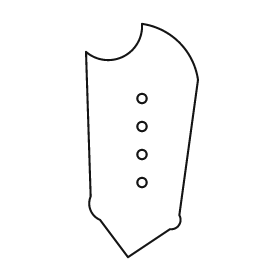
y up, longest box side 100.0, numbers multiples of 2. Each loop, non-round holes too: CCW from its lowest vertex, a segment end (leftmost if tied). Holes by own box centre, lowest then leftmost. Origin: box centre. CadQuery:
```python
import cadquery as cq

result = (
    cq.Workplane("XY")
    .moveTo(-6.0, -50.0)
    .lineTo(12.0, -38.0)
    .threePointArc((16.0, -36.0), (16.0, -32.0))
    .lineTo(24.0, 26.0)
    .threePointArc((16.0, 42.0), (0.0, 50.0))
    .threePointArc((-8.0, 36.0), (-24.0, 38.0))
    .lineTo(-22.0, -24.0)
    .threePointArc((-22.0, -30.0), (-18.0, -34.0))
    .close()
    .moveTo(0.0, -18.0)
    .circle(2.0)
    .moveTo(0.0, -6.0)
    .circle(2.0)
    .moveTo(0.0, 6.0)
    .circle(2.0)
    .moveTo(0.0, 18.0)
    .circle(2.0)
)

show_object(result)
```